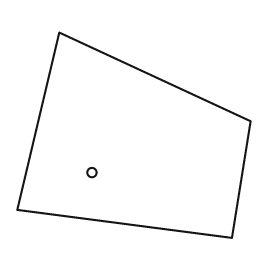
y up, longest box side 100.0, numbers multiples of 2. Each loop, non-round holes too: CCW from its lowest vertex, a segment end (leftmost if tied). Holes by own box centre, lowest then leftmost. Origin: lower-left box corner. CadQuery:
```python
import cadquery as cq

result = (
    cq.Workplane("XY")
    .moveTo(92.0, 0.0)
    .lineTo(100.0, 50.0)
    .lineTo(18.0, 88.0)
    .lineTo(0.0, 12.0)
    .close()
    .moveTo(32.0, 28.0)
    .circle(2.0)
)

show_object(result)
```